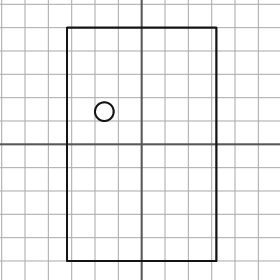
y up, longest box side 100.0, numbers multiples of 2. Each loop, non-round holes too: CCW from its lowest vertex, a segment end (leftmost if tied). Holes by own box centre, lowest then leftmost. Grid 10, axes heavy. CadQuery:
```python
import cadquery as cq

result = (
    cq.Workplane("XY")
    .moveTo(-32.0, -50.0)
    .lineTo(32.0, -50.0)
    .lineTo(32.0, 50.0)
    .lineTo(-32.0, 50.0)
    .close()
    .moveTo(-16.0, 14.0)
    .circle(4.0)
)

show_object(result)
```